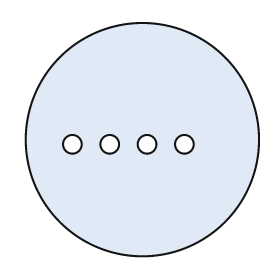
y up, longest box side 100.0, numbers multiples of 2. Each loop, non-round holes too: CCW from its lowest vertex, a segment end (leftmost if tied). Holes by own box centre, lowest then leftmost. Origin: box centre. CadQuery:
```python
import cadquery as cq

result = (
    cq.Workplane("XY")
    .moveTo(0.0, 0.0)
    .circle(50.0)
    .moveTo(-30.0, -2.0)
    .circle(4.0)
    .moveTo(-14.0, -2.0)
    .circle(4.0)
    .moveTo(2.0, -2.0)
    .circle(4.0)
    .moveTo(18.0, -2.0)
    .circle(4.0)
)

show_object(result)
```